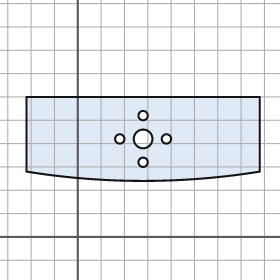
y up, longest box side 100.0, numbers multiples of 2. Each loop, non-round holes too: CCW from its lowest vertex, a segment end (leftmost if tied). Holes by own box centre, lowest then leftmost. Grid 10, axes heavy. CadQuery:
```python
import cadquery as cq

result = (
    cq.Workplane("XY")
    .moveTo(-22.0, 28.0)
    .threePointArc((28.0, 24.0), (78.0, 28.0))
    .lineTo(78.0, 60.0)
    .lineTo(-22.0, 60.0)
    .close()
    .moveTo(28.0, 32.0)
    .circle(2.0)
    .moveTo(18.0, 42.0)
    .circle(2.0)
    .moveTo(28.0, 42.0)
    .circle(4.0)
    .moveTo(38.0, 42.0)
    .circle(2.0)
    .moveTo(28.0, 52.0)
    .circle(2.0)
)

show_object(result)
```